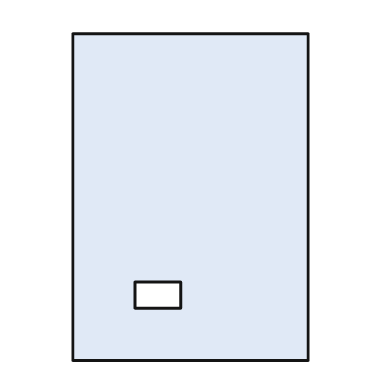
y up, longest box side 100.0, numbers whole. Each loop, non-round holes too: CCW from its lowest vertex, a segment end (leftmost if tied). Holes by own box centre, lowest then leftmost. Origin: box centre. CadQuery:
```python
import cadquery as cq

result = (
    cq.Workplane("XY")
    .moveTo(-36.0, -50.0)
    .lineTo(36.0, -50.0)
    .lineTo(36.0, 50.0)
    .lineTo(-36.0, 50.0)
    .close()
    .moveTo(-17.0, -34.0)
    .lineTo(-3.0, -34.0)
    .lineTo(-3.0, -26.0)
    .lineTo(-17.0, -26.0)
    .close()
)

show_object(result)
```